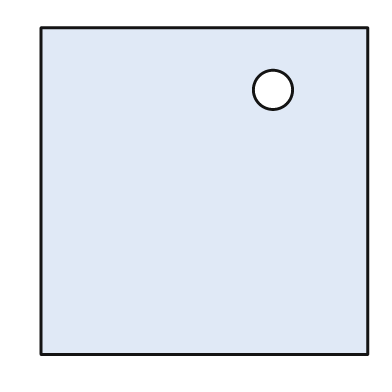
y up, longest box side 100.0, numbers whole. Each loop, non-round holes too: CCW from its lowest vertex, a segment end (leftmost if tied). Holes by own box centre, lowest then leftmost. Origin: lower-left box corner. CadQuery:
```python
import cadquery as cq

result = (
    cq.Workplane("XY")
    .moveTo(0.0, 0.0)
    .lineTo(100.0, 0.0)
    .lineTo(100.0, 100.0)
    .lineTo(0.0, 100.0)
    .close()
    .moveTo(71.0, 81.0)
    .circle(6.0)
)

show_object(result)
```